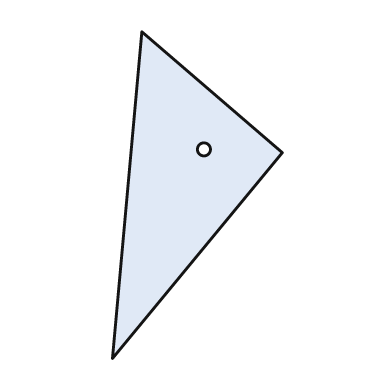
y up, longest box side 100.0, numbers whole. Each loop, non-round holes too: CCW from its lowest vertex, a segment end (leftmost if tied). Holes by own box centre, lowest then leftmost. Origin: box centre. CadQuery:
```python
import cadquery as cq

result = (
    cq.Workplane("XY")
    .moveTo(-26.0, -50.0)
    .lineTo(26.0, 13.0)
    .lineTo(-17.0, 50.0)
    .close()
    .moveTo(2.0, 14.0)
    .circle(2.0)
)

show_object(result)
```